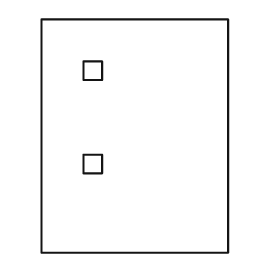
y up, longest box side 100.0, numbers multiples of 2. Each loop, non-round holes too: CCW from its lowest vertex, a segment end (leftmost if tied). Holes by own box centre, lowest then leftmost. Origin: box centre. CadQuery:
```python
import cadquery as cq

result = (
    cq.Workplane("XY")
    .moveTo(-40.0, -50.0)
    .lineTo(40.0, -50.0)
    .lineTo(40.0, 50.0)
    .lineTo(-40.0, 50.0)
    .close()
    .moveTo(-22.0, -16.0)
    .lineTo(-14.0, -16.0)
    .lineTo(-14.0, -8.0)
    .lineTo(-22.0, -8.0)
    .close()
    .moveTo(-22.0, 24.0)
    .lineTo(-14.0, 24.0)
    .lineTo(-14.0, 32.0)
    .lineTo(-22.0, 32.0)
    .close()
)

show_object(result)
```